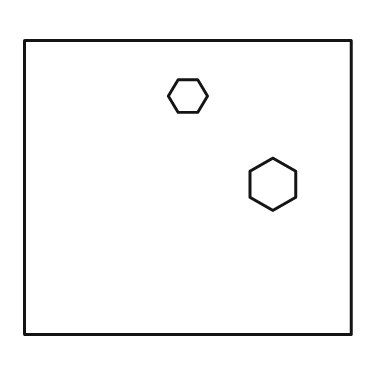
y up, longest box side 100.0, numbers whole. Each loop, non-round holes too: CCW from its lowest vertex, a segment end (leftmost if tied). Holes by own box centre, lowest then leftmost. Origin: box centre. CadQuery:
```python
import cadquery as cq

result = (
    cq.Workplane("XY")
    .moveTo(-50.0, -45.0)
    .lineTo(50.0, -45.0)
    .lineTo(50.0, 45.0)
    .lineTo(-50.0, 45.0)
    .close()
    .moveTo(26.0, -7.0)
    .lineTo(33.0, -3.0)
    .lineTo(33.0, 5.0)
    .lineTo(26.0, 9.0)
    .lineTo(19.0, 5.0)
    .lineTo(19.0, -3.0)
    .close()
    .moveTo(-3.0, 23.0)
    .lineTo(3.0, 23.0)
    .lineTo(6.0, 28.0)
    .lineTo(3.0, 33.0)
    .lineTo(-3.0, 33.0)
    .lineTo(-6.0, 28.0)
    .close()
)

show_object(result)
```